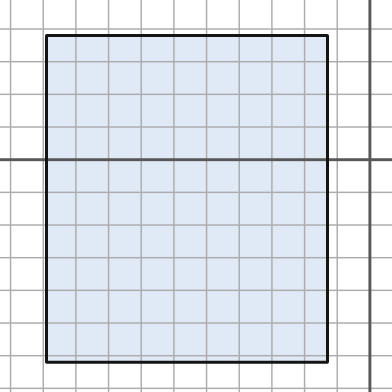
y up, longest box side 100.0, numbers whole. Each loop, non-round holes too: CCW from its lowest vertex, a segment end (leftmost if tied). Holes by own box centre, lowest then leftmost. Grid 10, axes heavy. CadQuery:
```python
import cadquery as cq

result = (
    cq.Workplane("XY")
    .moveTo(-99.0, -62.0)
    .lineTo(-13.0, -62.0)
    .lineTo(-13.0, 38.0)
    .lineTo(-99.0, 38.0)
    .close()
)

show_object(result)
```